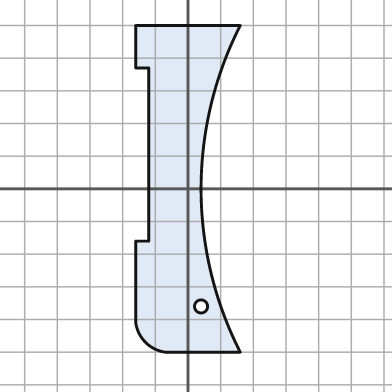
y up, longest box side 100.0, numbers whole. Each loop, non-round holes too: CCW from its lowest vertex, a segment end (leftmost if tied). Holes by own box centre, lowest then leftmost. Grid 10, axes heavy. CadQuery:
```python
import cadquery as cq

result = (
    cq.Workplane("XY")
    .moveTo(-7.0, -50.0)
    .lineTo(16.0, -50.0)
    .threePointArc((4.0, 0.0), (16.0, 50.0))
    .lineTo(-16.0, 50.0)
    .lineTo(-16.0, 37.0)
    .lineTo(-12.0, 37.0)
    .lineTo(-12.0, -16.0)
    .lineTo(-16.0, -16.0)
    .lineTo(-16.0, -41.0)
    .threePointArc((-13.0, -47.0), (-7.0, -50.0))
    .close()
    .moveTo(4.0, -36.0)
    .circle(2.0)
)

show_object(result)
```